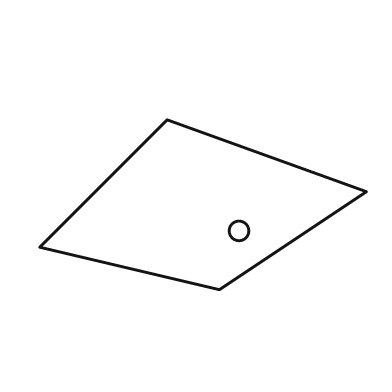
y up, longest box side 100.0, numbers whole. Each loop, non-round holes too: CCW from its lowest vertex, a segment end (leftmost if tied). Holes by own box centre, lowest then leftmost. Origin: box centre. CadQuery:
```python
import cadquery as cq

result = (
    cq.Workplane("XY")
    .moveTo(5.0, -26.0)
    .lineTo(50.0, 4.0)
    .lineTo(-11.0, 26.0)
    .lineTo(-50.0, -13.0)
    .close()
    .moveTo(11.0, -8.0)
    .circle(3.0)
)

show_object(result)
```